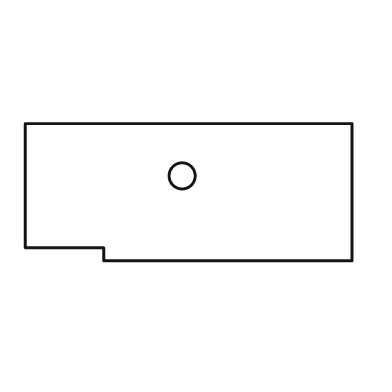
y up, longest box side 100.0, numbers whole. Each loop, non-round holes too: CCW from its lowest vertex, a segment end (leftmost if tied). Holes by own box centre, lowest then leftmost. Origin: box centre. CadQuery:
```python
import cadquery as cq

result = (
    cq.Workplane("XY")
    .moveTo(-26.0, -21.0)
    .lineTo(50.0, -21.0)
    .lineTo(50.0, 21.0)
    .lineTo(-50.0, 21.0)
    .lineTo(-50.0, -17.0)
    .lineTo(-26.0, -17.0)
    .close()
    .moveTo(-2.0, 5.0)
    .circle(4.0)
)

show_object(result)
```